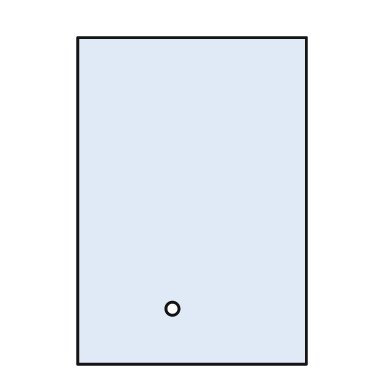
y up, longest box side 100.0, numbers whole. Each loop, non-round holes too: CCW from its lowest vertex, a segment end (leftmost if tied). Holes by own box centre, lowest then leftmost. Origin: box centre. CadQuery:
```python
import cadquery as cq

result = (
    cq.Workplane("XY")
    .moveTo(-35.0, -50.0)
    .lineTo(35.0, -50.0)
    .lineTo(35.0, 50.0)
    .lineTo(-35.0, 50.0)
    .close()
    .moveTo(-6.0, -33.0)
    .circle(2.0)
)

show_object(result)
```